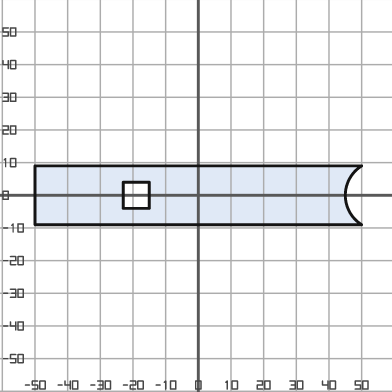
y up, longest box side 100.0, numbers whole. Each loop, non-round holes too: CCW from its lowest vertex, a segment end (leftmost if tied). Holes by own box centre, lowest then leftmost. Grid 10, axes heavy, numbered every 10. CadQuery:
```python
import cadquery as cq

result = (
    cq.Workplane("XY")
    .moveTo(-50.0, -9.0)
    .lineTo(50.0, -9.0)
    .threePointArc((45.0, 0.0), (50.0, 9.0))
    .lineTo(-50.0, 9.0)
    .close()
    .moveTo(-23.0, -4.0)
    .lineTo(-15.0, -4.0)
    .lineTo(-15.0, 4.0)
    .lineTo(-23.0, 4.0)
    .close()
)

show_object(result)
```